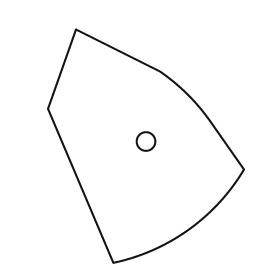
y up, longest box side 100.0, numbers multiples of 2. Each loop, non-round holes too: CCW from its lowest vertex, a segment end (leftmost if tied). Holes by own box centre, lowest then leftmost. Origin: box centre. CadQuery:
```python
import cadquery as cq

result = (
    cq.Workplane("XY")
    .moveTo(-14.0, -50.0)
    .threePointArc((18.0, -36.0), (42.0, -10.0))
    .lineTo(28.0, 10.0)
    .threePointArc((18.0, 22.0), (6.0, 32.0))
    .lineTo(-30.0, 50.0)
    .lineTo(-42.0, 16.0)
    .close()
    .moveTo(0.0, 2.0)
    .circle(4.0)
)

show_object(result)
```